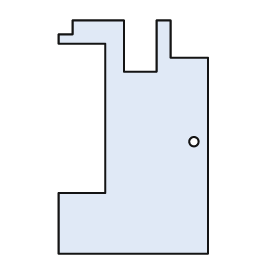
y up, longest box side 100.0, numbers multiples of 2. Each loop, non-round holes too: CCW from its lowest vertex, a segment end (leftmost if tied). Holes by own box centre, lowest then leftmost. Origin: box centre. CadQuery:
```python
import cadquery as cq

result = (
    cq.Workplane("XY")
    .moveTo(-32.0, -50.0)
    .lineTo(32.0, -50.0)
    .lineTo(32.0, 34.0)
    .lineTo(16.0, 34.0)
    .lineTo(16.0, 50.0)
    .lineTo(10.0, 50.0)
    .lineTo(10.0, 28.0)
    .lineTo(-4.0, 28.0)
    .lineTo(-4.0, 50.0)
    .lineTo(-26.0, 50.0)
    .lineTo(-26.0, 44.0)
    .lineTo(-32.0, 44.0)
    .lineTo(-32.0, 40.0)
    .lineTo(-12.0, 40.0)
    .lineTo(-12.0, -24.0)
    .lineTo(-32.0, -24.0)
    .close()
    .moveTo(26.0, -2.0)
    .circle(2.0)
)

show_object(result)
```